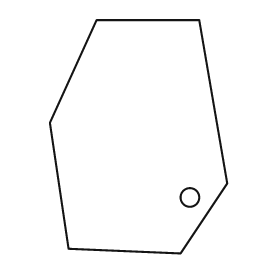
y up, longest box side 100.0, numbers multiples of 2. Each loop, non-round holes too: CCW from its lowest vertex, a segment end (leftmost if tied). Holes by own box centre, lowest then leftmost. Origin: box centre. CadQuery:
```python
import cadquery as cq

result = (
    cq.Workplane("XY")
    .moveTo(18.0, -50.0)
    .lineTo(38.0, -20.0)
    .lineTo(26.0, 50.0)
    .lineTo(-18.0, 50.0)
    .lineTo(-38.0, 6.0)
    .lineTo(-30.0, -48.0)
    .close()
    .moveTo(22.0, -26.0)
    .circle(4.0)
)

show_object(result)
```